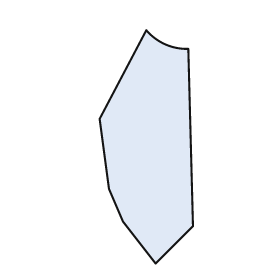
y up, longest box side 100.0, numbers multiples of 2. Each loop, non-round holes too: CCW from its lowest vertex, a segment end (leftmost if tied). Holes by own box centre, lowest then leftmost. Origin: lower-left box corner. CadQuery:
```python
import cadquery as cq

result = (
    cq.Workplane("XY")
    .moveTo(24.0, 0.0)
    .lineTo(40.0, 16.0)
    .lineTo(38.0, 92.0)
    .threePointArc((28.0, 94.0), (20.0, 100.0))
    .lineTo(0.0, 62.0)
    .lineTo(4.0, 32.0)
    .lineTo(10.0, 18.0)
    .close()
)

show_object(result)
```